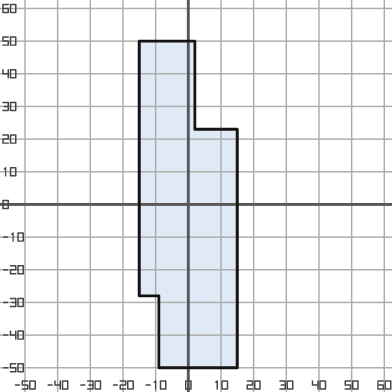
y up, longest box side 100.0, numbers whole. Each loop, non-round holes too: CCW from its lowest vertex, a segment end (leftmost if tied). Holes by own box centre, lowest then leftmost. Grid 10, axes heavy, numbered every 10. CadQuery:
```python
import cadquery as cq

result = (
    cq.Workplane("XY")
    .moveTo(-9.0, -50.0)
    .lineTo(15.0, -50.0)
    .lineTo(15.0, 23.0)
    .lineTo(2.0, 23.0)
    .lineTo(2.0, 50.0)
    .lineTo(-15.0, 50.0)
    .lineTo(-15.0, -28.0)
    .lineTo(-9.0, -28.0)
    .close()
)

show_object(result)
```